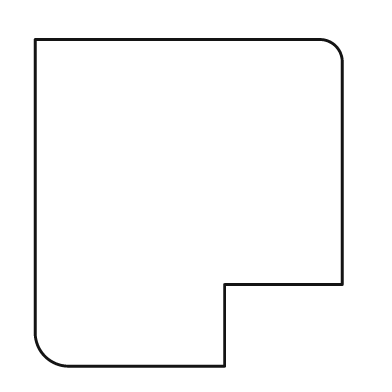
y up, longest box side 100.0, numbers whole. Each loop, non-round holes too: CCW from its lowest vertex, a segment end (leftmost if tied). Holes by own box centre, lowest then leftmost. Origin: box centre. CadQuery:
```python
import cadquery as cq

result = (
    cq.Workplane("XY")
    .moveTo(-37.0, -50.0)
    .lineTo(11.0, -50.0)
    .lineTo(11.0, -25.0)
    .lineTo(47.0, -25.0)
    .lineTo(47.0, 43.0)
    .threePointArc((45.0, 48.0), (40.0, 50.0))
    .lineTo(-47.0, 50.0)
    .lineTo(-47.0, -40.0)
    .threePointArc((-44.0, -47.0), (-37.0, -50.0))
    .close()
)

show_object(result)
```